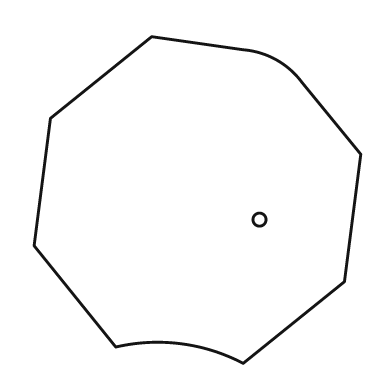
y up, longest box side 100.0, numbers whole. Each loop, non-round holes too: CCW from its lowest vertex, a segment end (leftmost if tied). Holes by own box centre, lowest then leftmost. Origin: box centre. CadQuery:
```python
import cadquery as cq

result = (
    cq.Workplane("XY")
    .moveTo(14.0, -50.0)
    .lineTo(45.0, -25.0)
    .lineTo(50.0, 14.0)
    .lineTo(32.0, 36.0)
    .threePointArc((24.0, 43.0), (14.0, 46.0))
    .lineTo(-14.0, 50.0)
    .lineTo(-45.0, 25.0)
    .lineTo(-50.0, -14.0)
    .lineTo(-25.0, -45.0)
    .threePointArc((-5.0, -44.0), (14.0, -50.0))
    .close()
    .moveTo(19.0, -6.0)
    .circle(2.0)
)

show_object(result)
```